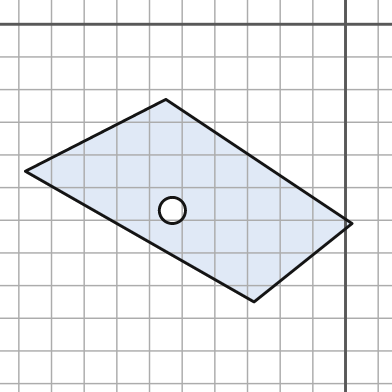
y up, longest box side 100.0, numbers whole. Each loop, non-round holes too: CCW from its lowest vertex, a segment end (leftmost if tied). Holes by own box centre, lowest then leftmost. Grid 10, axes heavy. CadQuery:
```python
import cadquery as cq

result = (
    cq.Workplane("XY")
    .moveTo(-28.0, -85.0)
    .lineTo(2.0, -61.0)
    .lineTo(-55.0, -23.0)
    .lineTo(-98.0, -45.0)
    .close()
    .moveTo(-53.0, -57.0)
    .circle(4.0)
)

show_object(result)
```